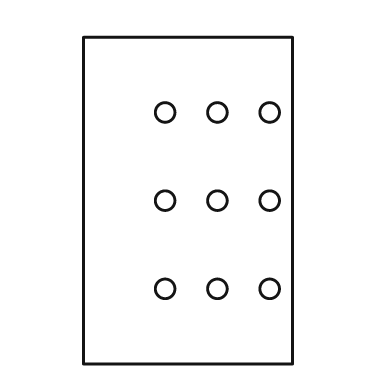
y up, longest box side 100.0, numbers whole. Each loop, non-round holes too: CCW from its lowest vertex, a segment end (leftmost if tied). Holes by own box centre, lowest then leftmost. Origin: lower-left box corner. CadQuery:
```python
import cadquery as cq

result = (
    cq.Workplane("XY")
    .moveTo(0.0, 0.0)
    .lineTo(64.0, 0.0)
    .lineTo(64.0, 100.0)
    .lineTo(0.0, 100.0)
    .close()
    .moveTo(25.0, 23.0)
    .circle(3.0)
    .moveTo(41.0, 23.0)
    .circle(3.0)
    .moveTo(57.0, 23.0)
    .circle(3.0)
    .moveTo(25.0, 50.0)
    .circle(3.0)
    .moveTo(41.0, 50.0)
    .circle(3.0)
    .moveTo(57.0, 50.0)
    .circle(3.0)
    .moveTo(25.0, 77.0)
    .circle(3.0)
    .moveTo(41.0, 77.0)
    .circle(3.0)
    .moveTo(57.0, 77.0)
    .circle(3.0)
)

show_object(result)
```